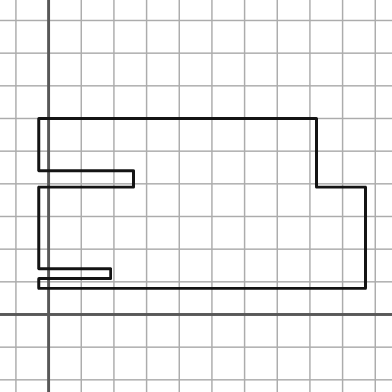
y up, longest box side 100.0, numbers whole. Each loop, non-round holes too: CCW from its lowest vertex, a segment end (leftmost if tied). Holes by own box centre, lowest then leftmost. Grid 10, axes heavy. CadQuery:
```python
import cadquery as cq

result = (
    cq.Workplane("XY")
    .moveTo(-3.0, 8.0)
    .lineTo(97.0, 8.0)
    .lineTo(97.0, 39.0)
    .lineTo(82.0, 39.0)
    .lineTo(82.0, 60.0)
    .lineTo(-3.0, 60.0)
    .lineTo(-3.0, 44.0)
    .lineTo(26.0, 44.0)
    .lineTo(26.0, 39.0)
    .lineTo(-3.0, 39.0)
    .lineTo(-3.0, 14.0)
    .lineTo(19.0, 14.0)
    .lineTo(19.0, 11.0)
    .lineTo(-3.0, 11.0)
    .close()
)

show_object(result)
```